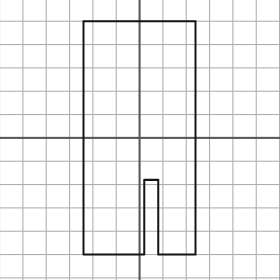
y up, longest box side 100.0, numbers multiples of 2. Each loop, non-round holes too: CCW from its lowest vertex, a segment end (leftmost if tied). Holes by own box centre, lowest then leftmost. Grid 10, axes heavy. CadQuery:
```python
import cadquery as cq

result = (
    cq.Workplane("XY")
    .moveTo(-24.0, -50.0)
    .lineTo(2.0, -50.0)
    .lineTo(2.0, -18.0)
    .lineTo(8.0, -18.0)
    .lineTo(8.0, -50.0)
    .lineTo(24.0, -50.0)
    .lineTo(24.0, 50.0)
    .lineTo(-24.0, 50.0)
    .close()
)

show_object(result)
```